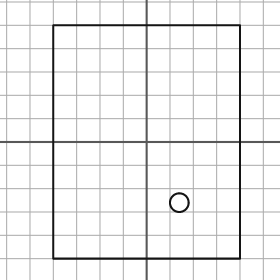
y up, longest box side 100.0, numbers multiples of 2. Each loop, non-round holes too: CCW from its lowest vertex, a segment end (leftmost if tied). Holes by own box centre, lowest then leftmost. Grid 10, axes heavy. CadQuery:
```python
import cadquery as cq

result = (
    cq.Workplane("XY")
    .moveTo(-40.0, -50.0)
    .lineTo(40.0, -50.0)
    .lineTo(40.0, 50.0)
    .lineTo(-40.0, 50.0)
    .close()
    .moveTo(14.0, -26.0)
    .circle(4.0)
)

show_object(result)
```